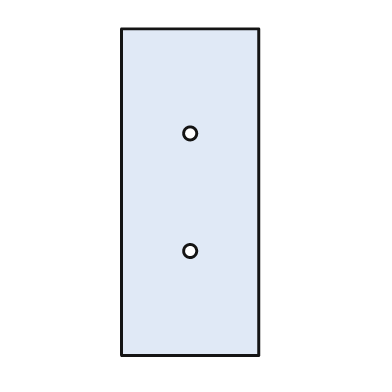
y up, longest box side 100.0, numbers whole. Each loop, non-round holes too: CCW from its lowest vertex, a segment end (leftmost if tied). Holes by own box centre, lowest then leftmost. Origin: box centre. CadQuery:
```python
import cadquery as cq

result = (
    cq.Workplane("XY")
    .moveTo(-21.0, -50.0)
    .lineTo(21.0, -50.0)
    .lineTo(21.0, 50.0)
    .lineTo(-21.0, 50.0)
    .close()
    .moveTo(0.0, -18.0)
    .circle(2.0)
    .moveTo(0.0, 18.0)
    .circle(2.0)
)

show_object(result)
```